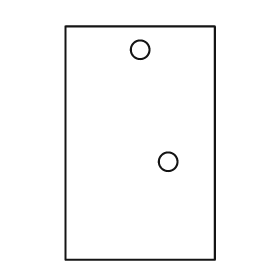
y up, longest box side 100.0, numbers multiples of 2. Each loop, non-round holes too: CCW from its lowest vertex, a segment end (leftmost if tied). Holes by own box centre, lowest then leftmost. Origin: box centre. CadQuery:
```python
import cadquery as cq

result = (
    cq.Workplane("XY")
    .moveTo(-32.0, -50.0)
    .lineTo(32.0, -50.0)
    .lineTo(32.0, 50.0)
    .lineTo(-32.0, 50.0)
    .close()
    .moveTo(12.0, -8.0)
    .circle(4.0)
    .moveTo(0.0, 40.0)
    .circle(4.0)
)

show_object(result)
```